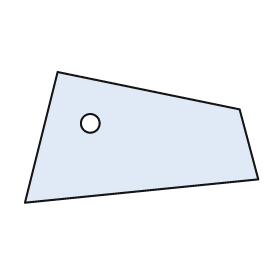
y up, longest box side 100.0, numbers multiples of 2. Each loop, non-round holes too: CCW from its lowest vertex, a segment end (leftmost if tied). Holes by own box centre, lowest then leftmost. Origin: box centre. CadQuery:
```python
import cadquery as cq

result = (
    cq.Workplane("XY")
    .moveTo(-50.0, -28.0)
    .lineTo(50.0, -18.0)
    .lineTo(42.0, 12.0)
    .lineTo(-36.0, 28.0)
    .close()
    .moveTo(-22.0, 6.0)
    .circle(4.0)
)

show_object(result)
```